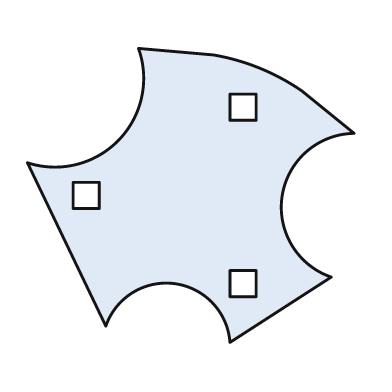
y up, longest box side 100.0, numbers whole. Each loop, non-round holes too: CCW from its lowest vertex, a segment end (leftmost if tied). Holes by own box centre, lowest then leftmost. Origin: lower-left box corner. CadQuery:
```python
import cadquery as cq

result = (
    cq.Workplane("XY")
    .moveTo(62.0, 0.0)
    .lineTo(93.0, 20.0)
    .threePointArc((78.0, 45.0), (100.0, 64.0))
    .lineTo(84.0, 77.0)
    .threePointArc((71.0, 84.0), (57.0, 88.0))
    .lineTo(34.0, 90.0)
    .threePointArc((28.0, 62.0), (0.0, 55.0))
    .lineTo(24.0, 5.0)
    .threePointArc((45.0, 18.0), (62.0, 0.0))
    .close()
    .moveTo(62.0, 14.0)
    .lineTo(70.0, 14.0)
    .lineTo(70.0, 22.0)
    .lineTo(62.0, 22.0)
    .close()
    .moveTo(14.0, 41.0)
    .lineTo(22.0, 41.0)
    .lineTo(22.0, 49.0)
    .lineTo(14.0, 49.0)
    .close()
    .moveTo(62.0, 68.0)
    .lineTo(70.0, 68.0)
    .lineTo(70.0, 76.0)
    .lineTo(62.0, 76.0)
    .close()
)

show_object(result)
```